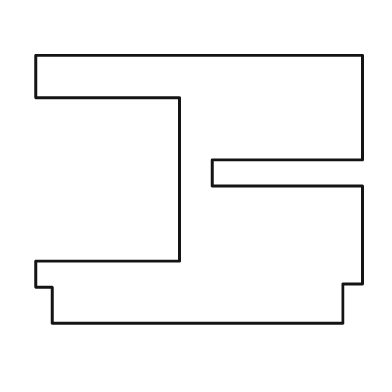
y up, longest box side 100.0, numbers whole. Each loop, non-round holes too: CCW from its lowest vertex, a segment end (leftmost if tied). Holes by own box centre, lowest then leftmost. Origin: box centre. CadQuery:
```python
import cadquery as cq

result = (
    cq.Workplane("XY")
    .moveTo(-45.0, -41.0)
    .lineTo(44.0, -41.0)
    .lineTo(44.0, -29.0)
    .lineTo(50.0, -29.0)
    .lineTo(50.0, 1.0)
    .lineTo(4.0, 1.0)
    .lineTo(4.0, 9.0)
    .lineTo(50.0, 9.0)
    .lineTo(50.0, 41.0)
    .lineTo(-50.0, 41.0)
    .lineTo(-50.0, 28.0)
    .lineTo(-6.0, 28.0)
    .lineTo(-6.0, -22.0)
    .lineTo(-50.0, -22.0)
    .lineTo(-50.0, -30.0)
    .lineTo(-45.0, -30.0)
    .close()
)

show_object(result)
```